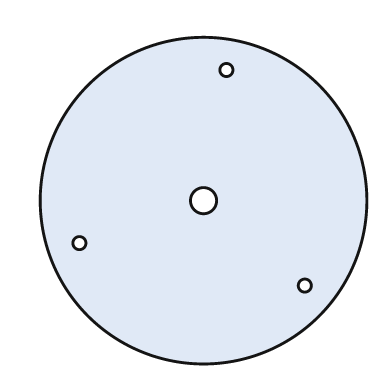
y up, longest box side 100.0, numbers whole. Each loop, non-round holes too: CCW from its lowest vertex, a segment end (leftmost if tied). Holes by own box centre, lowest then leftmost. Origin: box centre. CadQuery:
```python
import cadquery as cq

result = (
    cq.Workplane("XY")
    .moveTo(0.0, 0.0)
    .circle(50.0)
    .moveTo(31.0, -26.0)
    .circle(2.0)
    .moveTo(-38.0, -13.0)
    .circle(2.0)
    .moveTo(0.0, 0.0)
    .circle(4.0)
    .moveTo(7.0, 40.0)
    .circle(2.0)
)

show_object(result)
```